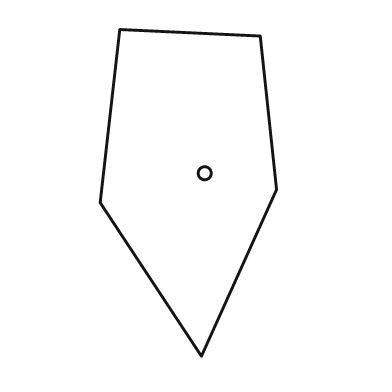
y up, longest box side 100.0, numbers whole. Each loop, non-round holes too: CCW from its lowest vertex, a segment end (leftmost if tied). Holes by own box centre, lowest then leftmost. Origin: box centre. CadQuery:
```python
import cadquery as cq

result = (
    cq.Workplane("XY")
    .moveTo(4.0, -50.0)
    .lineTo(27.0, 1.0)
    .lineTo(22.0, 48.0)
    .lineTo(-21.0, 50.0)
    .lineTo(-27.0, -3.0)
    .close()
    .moveTo(5.0, 6.0)
    .circle(2.0)
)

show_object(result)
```